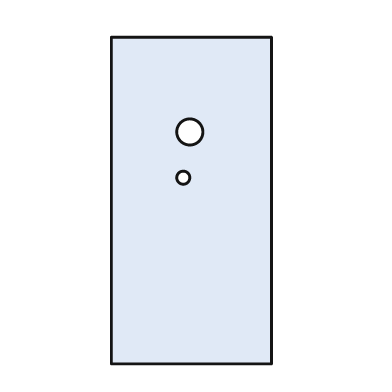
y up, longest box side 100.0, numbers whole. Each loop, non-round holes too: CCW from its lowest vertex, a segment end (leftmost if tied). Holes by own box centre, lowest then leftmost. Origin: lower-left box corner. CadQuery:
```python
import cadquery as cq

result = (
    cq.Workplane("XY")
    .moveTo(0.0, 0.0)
    .lineTo(49.0, 0.0)
    .lineTo(49.0, 100.0)
    .lineTo(0.0, 100.0)
    .close()
    .moveTo(22.0, 57.0)
    .circle(2.0)
    .moveTo(24.0, 71.0)
    .circle(4.0)
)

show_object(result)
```